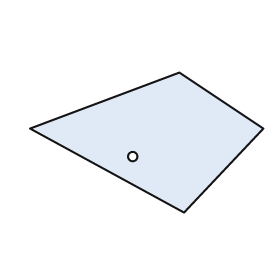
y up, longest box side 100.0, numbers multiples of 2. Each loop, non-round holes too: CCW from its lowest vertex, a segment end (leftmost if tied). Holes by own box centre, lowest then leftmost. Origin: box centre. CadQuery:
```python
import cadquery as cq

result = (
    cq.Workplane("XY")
    .moveTo(16.0, -30.0)
    .lineTo(50.0, 6.0)
    .lineTo(14.0, 30.0)
    .lineTo(-50.0, 6.0)
    .close()
    .moveTo(-6.0, -6.0)
    .circle(2.0)
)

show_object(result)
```